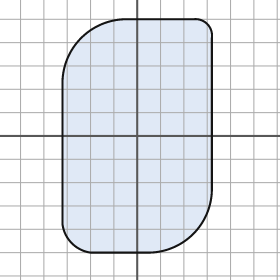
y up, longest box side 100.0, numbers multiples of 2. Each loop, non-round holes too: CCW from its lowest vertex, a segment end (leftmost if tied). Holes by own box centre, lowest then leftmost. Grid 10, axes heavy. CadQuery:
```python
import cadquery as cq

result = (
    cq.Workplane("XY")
    .moveTo(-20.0, -50.0)
    .lineTo(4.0, -50.0)
    .threePointArc((24.0, -42.0), (32.0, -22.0))
    .lineTo(32.0, 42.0)
    .threePointArc((30.0, 48.0), (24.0, 50.0))
    .lineTo(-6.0, 50.0)
    .threePointArc((-24.0, 42.0), (-32.0, 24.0))
    .lineTo(-32.0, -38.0)
    .threePointArc((-28.0, -46.0), (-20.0, -50.0))
    .close()
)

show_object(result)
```